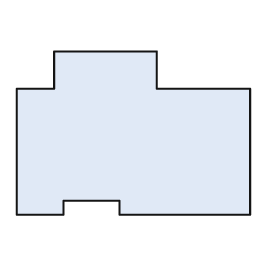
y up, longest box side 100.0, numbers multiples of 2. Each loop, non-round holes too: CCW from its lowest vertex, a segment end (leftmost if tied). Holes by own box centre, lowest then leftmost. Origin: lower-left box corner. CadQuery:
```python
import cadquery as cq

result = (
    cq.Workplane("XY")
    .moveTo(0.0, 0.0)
    .lineTo(20.0, 0.0)
    .lineTo(20.0, 6.0)
    .lineTo(44.0, 6.0)
    .lineTo(44.0, 0.0)
    .lineTo(100.0, 0.0)
    .lineTo(100.0, 54.0)
    .lineTo(60.0, 54.0)
    .lineTo(60.0, 70.0)
    .lineTo(16.0, 70.0)
    .lineTo(16.0, 54.0)
    .lineTo(0.0, 54.0)
    .close()
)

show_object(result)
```